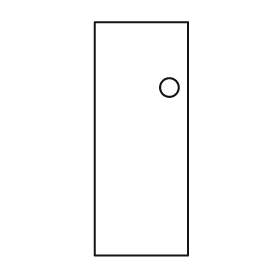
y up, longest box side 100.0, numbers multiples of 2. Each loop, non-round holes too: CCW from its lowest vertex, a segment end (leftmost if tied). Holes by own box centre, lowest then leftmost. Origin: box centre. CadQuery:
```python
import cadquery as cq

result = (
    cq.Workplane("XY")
    .moveTo(-20.0, -50.0)
    .lineTo(20.0, -50.0)
    .lineTo(20.0, 50.0)
    .lineTo(-20.0, 50.0)
    .close()
    .moveTo(12.0, 22.0)
    .circle(4.0)
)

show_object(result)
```